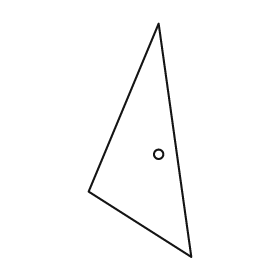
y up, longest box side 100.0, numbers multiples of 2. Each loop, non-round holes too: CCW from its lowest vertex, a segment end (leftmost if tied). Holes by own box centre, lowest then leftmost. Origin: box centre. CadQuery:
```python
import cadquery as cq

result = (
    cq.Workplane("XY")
    .moveTo(22.0, -50.0)
    .lineTo(8.0, 50.0)
    .lineTo(-22.0, -22.0)
    .close()
    .moveTo(8.0, -6.0)
    .circle(2.0)
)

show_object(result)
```